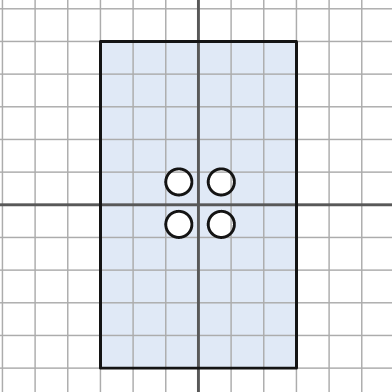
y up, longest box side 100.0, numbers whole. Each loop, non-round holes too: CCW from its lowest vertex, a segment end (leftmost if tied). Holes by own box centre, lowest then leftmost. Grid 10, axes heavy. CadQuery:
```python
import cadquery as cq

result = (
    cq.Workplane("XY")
    .moveTo(-30.0, -50.0)
    .lineTo(30.0, -50.0)
    .lineTo(30.0, 50.0)
    .lineTo(-30.0, 50.0)
    .close()
    .moveTo(-6.0, -6.0)
    .circle(4.0)
    .moveTo(7.0, -6.0)
    .circle(4.0)
    .moveTo(-6.0, 7.0)
    .circle(4.0)
    .moveTo(7.0, 7.0)
    .circle(4.0)
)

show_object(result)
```